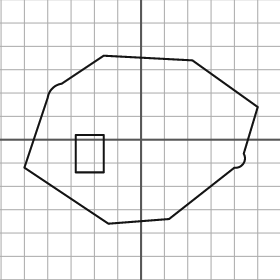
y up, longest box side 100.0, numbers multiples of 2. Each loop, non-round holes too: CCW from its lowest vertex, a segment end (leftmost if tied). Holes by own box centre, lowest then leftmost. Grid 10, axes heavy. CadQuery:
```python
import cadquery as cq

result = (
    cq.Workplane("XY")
    .moveTo(-14.0, -36.0)
    .lineTo(12.0, -34.0)
    .lineTo(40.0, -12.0)
    .threePointArc((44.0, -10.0), (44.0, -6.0))
    .lineTo(50.0, 14.0)
    .lineTo(22.0, 34.0)
    .lineTo(-16.0, 36.0)
    .lineTo(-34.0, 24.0)
    .threePointArc((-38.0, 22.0), (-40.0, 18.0))
    .lineTo(-50.0, -12.0)
    .close()
    .moveTo(-28.0, -14.0)
    .lineTo(-16.0, -14.0)
    .lineTo(-16.0, 2.0)
    .lineTo(-28.0, 2.0)
    .close()
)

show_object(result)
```